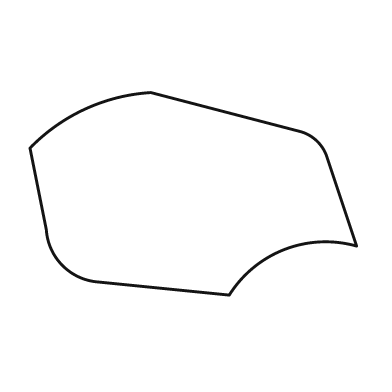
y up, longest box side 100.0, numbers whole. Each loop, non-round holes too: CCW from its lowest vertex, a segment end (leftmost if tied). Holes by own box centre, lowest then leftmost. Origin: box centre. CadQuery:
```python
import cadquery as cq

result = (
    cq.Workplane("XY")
    .moveTo(11.0, -31.0)
    .threePointArc((28.0, -17.0), (50.0, -16.0))
    .lineTo(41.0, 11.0)
    .threePointArc((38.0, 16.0), (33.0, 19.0))
    .lineTo(-13.0, 31.0)
    .threePointArc((-33.0, 26.0), (-50.0, 14.0))
    .lineTo(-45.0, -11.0)
    .threePointArc((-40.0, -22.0), (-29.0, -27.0))
    .close()
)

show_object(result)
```